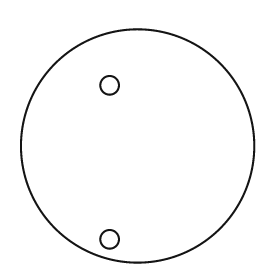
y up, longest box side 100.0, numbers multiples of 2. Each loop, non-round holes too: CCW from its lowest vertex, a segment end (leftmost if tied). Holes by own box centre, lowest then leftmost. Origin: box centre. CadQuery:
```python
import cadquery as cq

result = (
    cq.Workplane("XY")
    .moveTo(0.0, 0.0)
    .circle(50.0)
    .moveTo(-12.0, -40.0)
    .circle(4.0)
    .moveTo(-12.0, 26.0)
    .circle(4.0)
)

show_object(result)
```